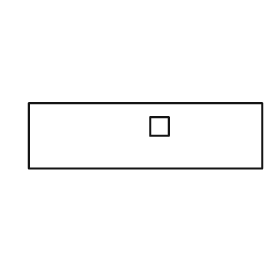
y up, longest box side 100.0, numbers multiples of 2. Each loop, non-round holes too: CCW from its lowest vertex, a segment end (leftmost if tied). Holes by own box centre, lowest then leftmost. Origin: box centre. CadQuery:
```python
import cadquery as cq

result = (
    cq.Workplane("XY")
    .moveTo(-50.0, -14.0)
    .lineTo(50.0, -14.0)
    .lineTo(50.0, 14.0)
    .lineTo(-50.0, 14.0)
    .close()
    .moveTo(2.0, 0.0)
    .lineTo(10.0, 0.0)
    .lineTo(10.0, 8.0)
    .lineTo(2.0, 8.0)
    .close()
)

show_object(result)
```